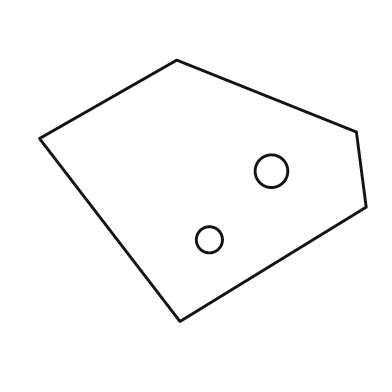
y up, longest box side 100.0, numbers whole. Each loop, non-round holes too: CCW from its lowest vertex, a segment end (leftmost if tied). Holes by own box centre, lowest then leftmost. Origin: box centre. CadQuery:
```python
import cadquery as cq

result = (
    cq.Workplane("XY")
    .moveTo(-7.0, -40.0)
    .lineTo(50.0, -5.0)
    .lineTo(47.0, 18.0)
    .lineTo(-8.0, 40.0)
    .lineTo(-50.0, 16.0)
    .close()
    .moveTo(2.0, -15.0)
    .circle(4.0)
    .moveTo(21.0, 6.0)
    .circle(5.0)
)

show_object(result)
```